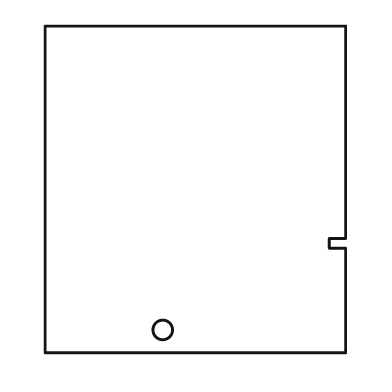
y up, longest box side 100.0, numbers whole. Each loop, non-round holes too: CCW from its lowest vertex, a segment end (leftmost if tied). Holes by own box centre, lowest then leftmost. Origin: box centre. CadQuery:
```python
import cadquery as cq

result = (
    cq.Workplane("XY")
    .moveTo(-46.0, -50.0)
    .lineTo(46.0, -50.0)
    .lineTo(46.0, -18.0)
    .lineTo(41.0, -18.0)
    .lineTo(41.0, -15.0)
    .lineTo(46.0, -15.0)
    .lineTo(46.0, 50.0)
    .lineTo(-46.0, 50.0)
    .close()
    .moveTo(-10.0, -43.0)
    .circle(3.0)
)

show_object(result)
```